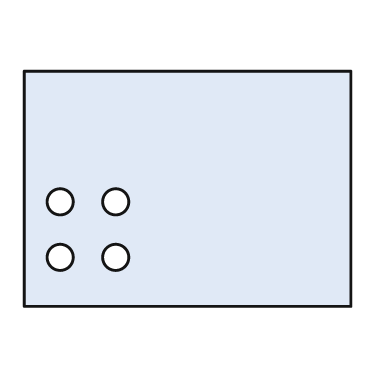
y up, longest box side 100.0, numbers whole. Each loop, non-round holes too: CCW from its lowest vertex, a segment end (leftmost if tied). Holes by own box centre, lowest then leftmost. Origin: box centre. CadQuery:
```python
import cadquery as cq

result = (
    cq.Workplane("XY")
    .moveTo(-50.0, -36.0)
    .lineTo(50.0, -36.0)
    .lineTo(50.0, 36.0)
    .lineTo(-50.0, 36.0)
    .close()
    .moveTo(-39.0, -21.0)
    .circle(4.0)
    .moveTo(-22.0, -21.0)
    .circle(4.0)
    .moveTo(-39.0, -4.0)
    .circle(4.0)
    .moveTo(-22.0, -4.0)
    .circle(4.0)
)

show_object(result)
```